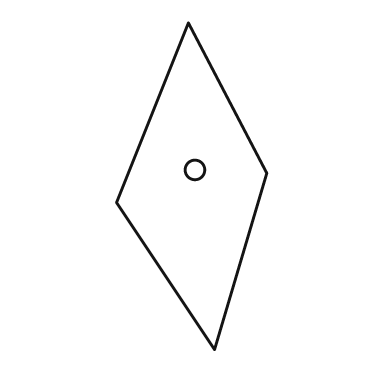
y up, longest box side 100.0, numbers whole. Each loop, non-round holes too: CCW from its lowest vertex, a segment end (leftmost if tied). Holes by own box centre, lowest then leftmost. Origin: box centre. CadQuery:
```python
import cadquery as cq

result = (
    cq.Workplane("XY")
    .moveTo(7.0, -50.0)
    .lineTo(23.0, 4.0)
    .lineTo(-1.0, 50.0)
    .lineTo(-23.0, -5.0)
    .close()
    .moveTo(1.0, 5.0)
    .circle(3.0)
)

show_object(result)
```